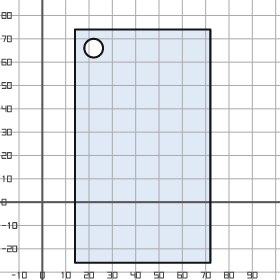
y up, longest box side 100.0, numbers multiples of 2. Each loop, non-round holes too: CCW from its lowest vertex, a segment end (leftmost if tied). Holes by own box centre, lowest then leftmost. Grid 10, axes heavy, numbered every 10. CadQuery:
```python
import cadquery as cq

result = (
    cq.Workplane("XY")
    .moveTo(14.0, -26.0)
    .lineTo(72.0, -26.0)
    .lineTo(72.0, 74.0)
    .lineTo(14.0, 74.0)
    .close()
    .moveTo(22.0, 66.0)
    .circle(4.0)
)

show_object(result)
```